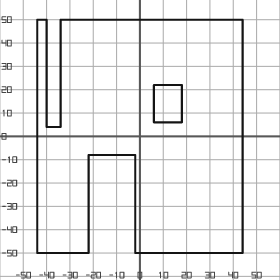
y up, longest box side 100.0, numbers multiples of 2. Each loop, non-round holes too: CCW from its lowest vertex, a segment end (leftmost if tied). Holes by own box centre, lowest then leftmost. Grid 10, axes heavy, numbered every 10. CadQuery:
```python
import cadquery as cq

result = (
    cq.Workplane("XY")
    .moveTo(-44.0, -50.0)
    .lineTo(-22.0, -50.0)
    .lineTo(-22.0, -8.0)
    .lineTo(-2.0, -8.0)
    .lineTo(-2.0, -50.0)
    .lineTo(44.0, -50.0)
    .lineTo(44.0, 50.0)
    .lineTo(-34.0, 50.0)
    .lineTo(-34.0, 4.0)
    .lineTo(-40.0, 4.0)
    .lineTo(-40.0, 50.0)
    .lineTo(-44.0, 50.0)
    .close()
    .moveTo(6.0, 6.0)
    .lineTo(18.0, 6.0)
    .lineTo(18.0, 22.0)
    .lineTo(6.0, 22.0)
    .close()
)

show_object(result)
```